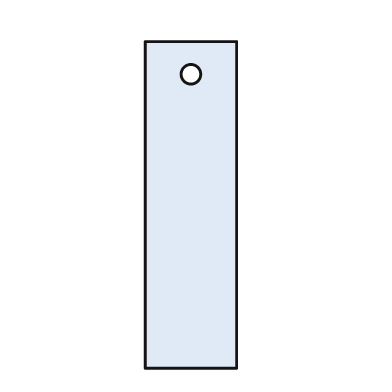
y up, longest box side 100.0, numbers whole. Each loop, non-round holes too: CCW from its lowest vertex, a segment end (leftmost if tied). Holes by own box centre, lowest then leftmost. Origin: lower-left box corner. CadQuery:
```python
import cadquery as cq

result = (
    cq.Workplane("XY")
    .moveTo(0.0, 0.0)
    .lineTo(28.0, 0.0)
    .lineTo(28.0, 100.0)
    .lineTo(0.0, 100.0)
    .close()
    .moveTo(14.0, 90.0)
    .circle(3.0)
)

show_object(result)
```